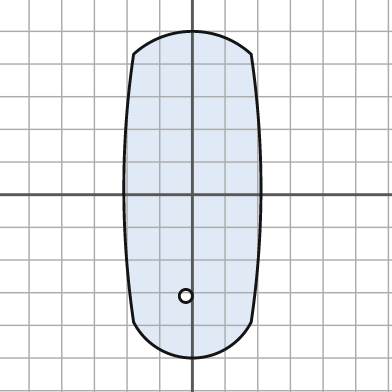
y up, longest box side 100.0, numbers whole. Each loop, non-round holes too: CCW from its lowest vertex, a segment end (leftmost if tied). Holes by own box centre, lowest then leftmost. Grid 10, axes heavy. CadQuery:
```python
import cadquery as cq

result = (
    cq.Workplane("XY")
    .moveTo(-18.0, -39.0)
    .threePointArc((0.0, -50.0), (18.0, -39.0))
    .threePointArc((21.0, 2.0), (18.0, 43.0))
    .threePointArc((0.0, 50.0), (-18.0, 43.0))
    .threePointArc((-21.0, 2.0), (-18.0, -39.0))
    .close()
    .moveTo(-2.0, -31.0)
    .circle(2.0)
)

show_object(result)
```